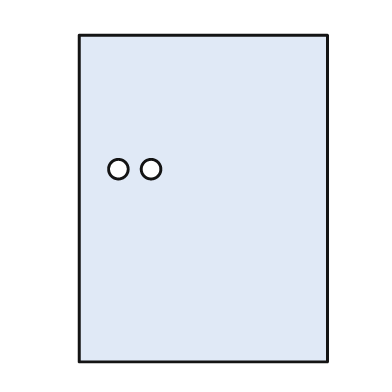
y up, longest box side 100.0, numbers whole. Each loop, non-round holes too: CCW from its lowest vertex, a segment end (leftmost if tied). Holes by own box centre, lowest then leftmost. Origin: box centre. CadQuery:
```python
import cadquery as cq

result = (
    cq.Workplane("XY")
    .moveTo(-38.0, -50.0)
    .lineTo(38.0, -50.0)
    .lineTo(38.0, 50.0)
    .lineTo(-38.0, 50.0)
    .close()
    .moveTo(-26.0, 9.0)
    .circle(3.0)
    .moveTo(-16.0, 9.0)
    .circle(3.0)
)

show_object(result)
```